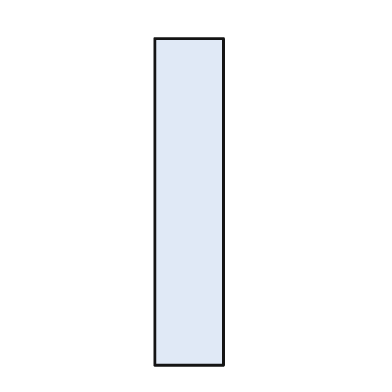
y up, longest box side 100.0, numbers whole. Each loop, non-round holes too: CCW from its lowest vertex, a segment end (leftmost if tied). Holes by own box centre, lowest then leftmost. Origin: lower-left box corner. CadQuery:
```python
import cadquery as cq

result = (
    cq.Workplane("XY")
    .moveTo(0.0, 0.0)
    .lineTo(21.0, 0.0)
    .lineTo(21.0, 100.0)
    .lineTo(0.0, 100.0)
    .close()
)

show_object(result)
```